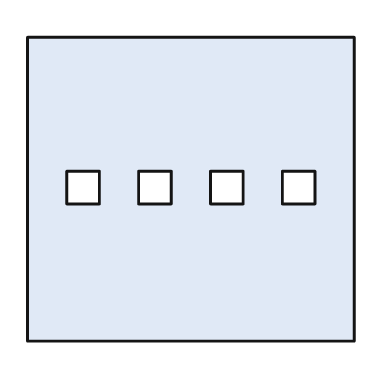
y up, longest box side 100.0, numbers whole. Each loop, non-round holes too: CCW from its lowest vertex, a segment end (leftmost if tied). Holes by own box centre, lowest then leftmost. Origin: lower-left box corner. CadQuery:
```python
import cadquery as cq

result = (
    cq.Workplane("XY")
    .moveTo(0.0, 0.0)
    .lineTo(100.0, 0.0)
    .lineTo(100.0, 93.0)
    .lineTo(0.0, 93.0)
    .close()
    .moveTo(12.0, 42.0)
    .lineTo(22.0, 42.0)
    .lineTo(22.0, 52.0)
    .lineTo(12.0, 52.0)
    .close()
    .moveTo(34.0, 42.0)
    .lineTo(44.0, 42.0)
    .lineTo(44.0, 52.0)
    .lineTo(34.0, 52.0)
    .close()
    .moveTo(56.0, 42.0)
    .lineTo(66.0, 42.0)
    .lineTo(66.0, 52.0)
    .lineTo(56.0, 52.0)
    .close()
    .moveTo(78.0, 42.0)
    .lineTo(88.0, 42.0)
    .lineTo(88.0, 52.0)
    .lineTo(78.0, 52.0)
    .close()
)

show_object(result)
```